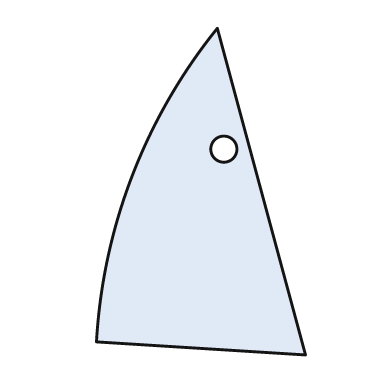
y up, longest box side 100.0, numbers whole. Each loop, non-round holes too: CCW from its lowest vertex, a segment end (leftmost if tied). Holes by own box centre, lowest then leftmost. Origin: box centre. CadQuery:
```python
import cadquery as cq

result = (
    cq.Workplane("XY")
    .moveTo(32.0, -50.0)
    .lineTo(5.0, 50.0)
    .threePointArc((-21.0, 5.0), (-32.0, -46.0))
    .close()
    .moveTo(7.0, 13.0)
    .circle(4.0)
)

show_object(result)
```